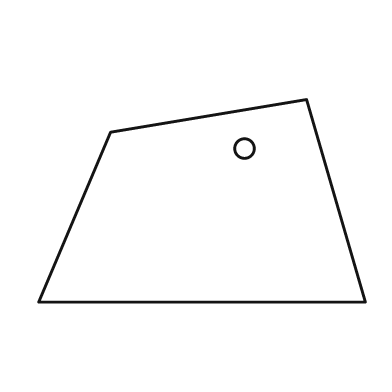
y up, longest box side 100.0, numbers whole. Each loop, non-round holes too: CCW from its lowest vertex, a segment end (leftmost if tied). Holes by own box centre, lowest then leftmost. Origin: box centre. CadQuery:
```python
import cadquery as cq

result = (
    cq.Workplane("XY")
    .moveTo(-50.0, -31.0)
    .lineTo(50.0, -31.0)
    .lineTo(32.0, 31.0)
    .lineTo(-28.0, 21.0)
    .close()
    .moveTo(13.0, 16.0)
    .circle(3.0)
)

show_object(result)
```